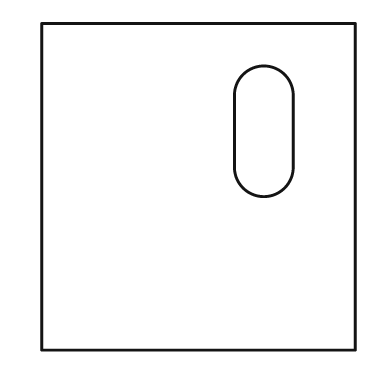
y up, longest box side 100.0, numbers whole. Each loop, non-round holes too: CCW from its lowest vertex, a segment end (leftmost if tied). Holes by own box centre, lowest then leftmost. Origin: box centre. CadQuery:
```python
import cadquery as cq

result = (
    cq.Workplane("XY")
    .moveTo(-48.0, -50.0)
    .lineTo(48.0, -50.0)
    .lineTo(48.0, 50.0)
    .lineTo(-48.0, 50.0)
    .close()
    .moveTo(11.0, 6.0)
    .threePointArc((20.0, -3.0), (29.0, 6.0))
    .lineTo(29.0, 28.0)
    .threePointArc((20.0, 37.0), (11.0, 28.0))
    .close()
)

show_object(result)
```